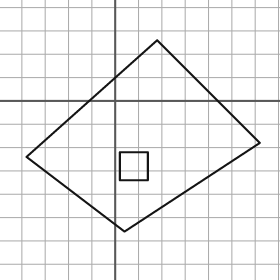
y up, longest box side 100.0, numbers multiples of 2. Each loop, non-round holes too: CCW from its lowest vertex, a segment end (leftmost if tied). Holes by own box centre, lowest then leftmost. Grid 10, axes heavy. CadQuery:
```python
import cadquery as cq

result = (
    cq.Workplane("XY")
    .moveTo(4.0, -56.0)
    .lineTo(62.0, -18.0)
    .lineTo(18.0, 26.0)
    .lineTo(-38.0, -24.0)
    .close()
    .moveTo(2.0, -34.0)
    .lineTo(14.0, -34.0)
    .lineTo(14.0, -22.0)
    .lineTo(2.0, -22.0)
    .close()
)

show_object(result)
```